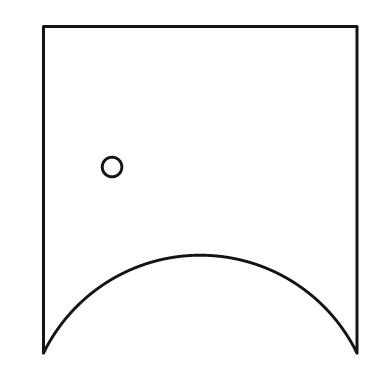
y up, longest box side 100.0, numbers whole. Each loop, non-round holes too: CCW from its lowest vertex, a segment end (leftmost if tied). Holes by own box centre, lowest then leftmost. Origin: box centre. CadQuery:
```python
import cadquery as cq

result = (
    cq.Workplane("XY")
    .moveTo(-48.0, -50.0)
    .threePointArc((0.0, -20.0), (48.0, -50.0))
    .lineTo(48.0, 50.0)
    .lineTo(-48.0, 50.0)
    .close()
    .moveTo(-27.0, 7.0)
    .circle(3.0)
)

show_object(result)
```